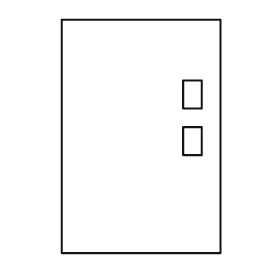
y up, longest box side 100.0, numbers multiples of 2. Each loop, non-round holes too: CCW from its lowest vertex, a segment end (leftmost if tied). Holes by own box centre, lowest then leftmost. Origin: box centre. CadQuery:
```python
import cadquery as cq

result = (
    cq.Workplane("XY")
    .moveTo(-34.0, -50.0)
    .lineTo(34.0, -50.0)
    .lineTo(34.0, 50.0)
    .lineTo(-34.0, 50.0)
    .close()
    .moveTo(18.0, -8.0)
    .lineTo(26.0, -8.0)
    .lineTo(26.0, 4.0)
    .lineTo(18.0, 4.0)
    .close()
    .moveTo(18.0, 12.0)
    .lineTo(26.0, 12.0)
    .lineTo(26.0, 24.0)
    .lineTo(18.0, 24.0)
    .close()
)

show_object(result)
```